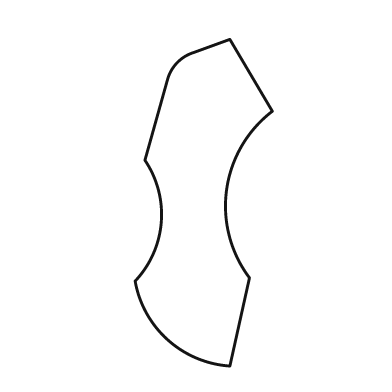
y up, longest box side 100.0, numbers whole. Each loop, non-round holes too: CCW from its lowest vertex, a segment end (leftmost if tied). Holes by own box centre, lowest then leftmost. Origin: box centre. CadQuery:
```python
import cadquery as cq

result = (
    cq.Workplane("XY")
    .moveTo(8.0, -50.0)
    .lineTo(14.0, -23.0)
    .threePointArc((7.0, 4.0), (21.0, 28.0))
    .lineTo(8.0, 50.0)
    .lineTo(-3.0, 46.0)
    .threePointArc((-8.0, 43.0), (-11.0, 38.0))
    .lineTo(-18.0, 13.0)
    .threePointArc((-13.0, -6.0), (-21.0, -24.0))
    .threePointArc((-11.0, -42.0), (8.0, -50.0))
    .close()
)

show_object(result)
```